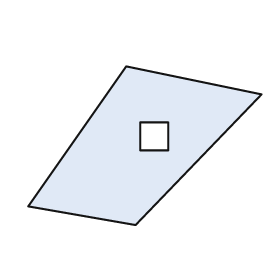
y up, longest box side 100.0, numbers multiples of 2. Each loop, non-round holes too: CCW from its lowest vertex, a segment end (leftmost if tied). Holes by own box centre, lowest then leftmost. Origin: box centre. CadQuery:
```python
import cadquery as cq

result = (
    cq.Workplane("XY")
    .moveTo(-4.0, -34.0)
    .lineTo(50.0, 22.0)
    .lineTo(-8.0, 34.0)
    .lineTo(-50.0, -26.0)
    .close()
    .moveTo(-2.0, -2.0)
    .lineTo(10.0, -2.0)
    .lineTo(10.0, 10.0)
    .lineTo(-2.0, 10.0)
    .close()
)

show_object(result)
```